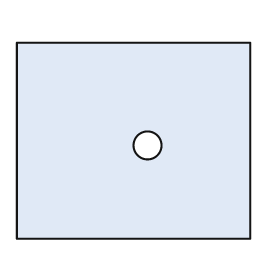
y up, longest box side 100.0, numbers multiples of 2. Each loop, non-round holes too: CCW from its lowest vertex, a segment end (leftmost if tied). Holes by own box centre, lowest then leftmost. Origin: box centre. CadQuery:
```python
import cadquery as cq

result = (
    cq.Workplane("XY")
    .moveTo(-50.0, -42.0)
    .lineTo(50.0, -42.0)
    .lineTo(50.0, 42.0)
    .lineTo(-50.0, 42.0)
    .close()
    .moveTo(6.0, -2.0)
    .circle(6.0)
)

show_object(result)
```